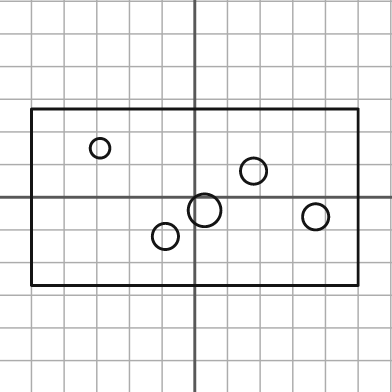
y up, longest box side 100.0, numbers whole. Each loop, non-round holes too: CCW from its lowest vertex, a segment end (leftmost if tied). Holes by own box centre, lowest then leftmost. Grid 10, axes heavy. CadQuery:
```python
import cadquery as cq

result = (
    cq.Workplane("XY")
    .moveTo(-50.0, -27.0)
    .lineTo(50.0, -27.0)
    .lineTo(50.0, 27.0)
    .lineTo(-50.0, 27.0)
    .close()
    .moveTo(-9.0, -12.0)
    .circle(4.0)
    .moveTo(37.0, -6.0)
    .circle(4.0)
    .moveTo(3.0, -4.0)
    .circle(5.0)
    .moveTo(18.0, 8.0)
    .circle(4.0)
    .moveTo(-29.0, 15.0)
    .circle(3.0)
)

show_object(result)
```